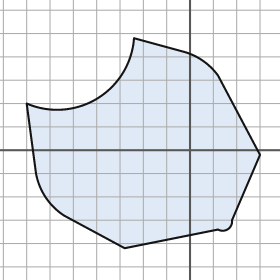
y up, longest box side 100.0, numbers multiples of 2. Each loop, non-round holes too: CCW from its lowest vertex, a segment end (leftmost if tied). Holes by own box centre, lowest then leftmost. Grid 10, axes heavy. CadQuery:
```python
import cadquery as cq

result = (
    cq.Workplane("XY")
    .moveTo(-28.0, -42.0)
    .lineTo(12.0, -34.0)
    .threePointArc((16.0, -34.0), (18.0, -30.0))
    .lineTo(30.0, -2.0)
    .lineTo(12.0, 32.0)
    .threePointArc((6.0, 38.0), (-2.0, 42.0))
    .lineTo(-24.0, 48.0)
    .threePointArc((-40.0, 22.0), (-70.0, 20.0))
    .lineTo(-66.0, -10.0)
    .threePointArc((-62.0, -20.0), (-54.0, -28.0))
    .close()
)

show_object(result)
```